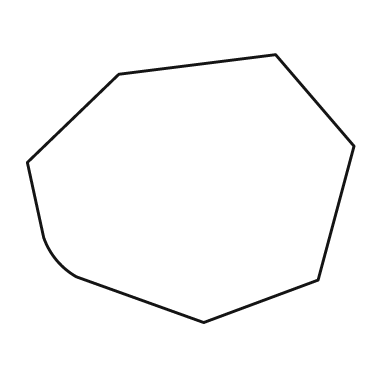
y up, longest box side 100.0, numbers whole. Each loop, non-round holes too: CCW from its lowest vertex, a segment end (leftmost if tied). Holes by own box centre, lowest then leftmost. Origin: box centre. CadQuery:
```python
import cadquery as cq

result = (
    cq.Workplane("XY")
    .moveTo(4.0, -41.0)
    .lineTo(39.0, -28.0)
    .lineTo(50.0, 13.0)
    .lineTo(26.0, 41.0)
    .lineTo(-22.0, 35.0)
    .lineTo(-50.0, 8.0)
    .lineTo(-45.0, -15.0)
    .threePointArc((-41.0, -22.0), (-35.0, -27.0))
    .close()
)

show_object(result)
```